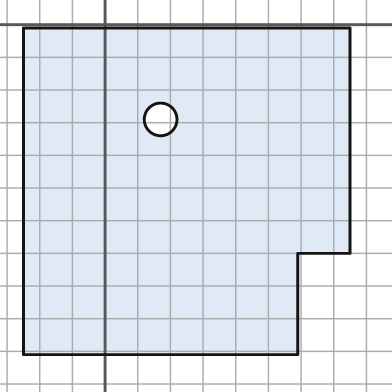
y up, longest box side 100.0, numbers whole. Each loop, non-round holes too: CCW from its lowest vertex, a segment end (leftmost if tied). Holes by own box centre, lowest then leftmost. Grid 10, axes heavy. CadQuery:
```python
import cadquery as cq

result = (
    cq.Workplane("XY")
    .moveTo(-25.0, -101.0)
    .lineTo(59.0, -101.0)
    .lineTo(59.0, -70.0)
    .lineTo(75.0, -70.0)
    .lineTo(75.0, -1.0)
    .lineTo(-25.0, -1.0)
    .close()
    .moveTo(17.0, -29.0)
    .circle(5.0)
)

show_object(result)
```